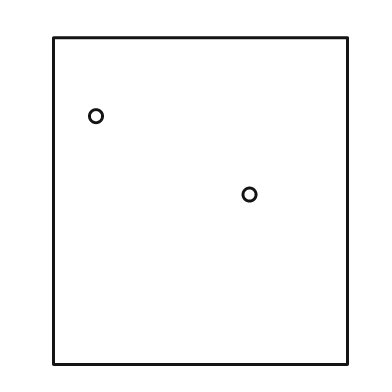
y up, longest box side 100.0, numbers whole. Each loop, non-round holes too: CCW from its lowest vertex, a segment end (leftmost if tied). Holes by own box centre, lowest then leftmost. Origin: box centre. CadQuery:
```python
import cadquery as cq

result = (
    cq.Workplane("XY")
    .moveTo(-45.0, -50.0)
    .lineTo(45.0, -50.0)
    .lineTo(45.0, 50.0)
    .lineTo(-45.0, 50.0)
    .close()
    .moveTo(15.0, 2.0)
    .circle(2.0)
    .moveTo(-32.0, 26.0)
    .circle(2.0)
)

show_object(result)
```